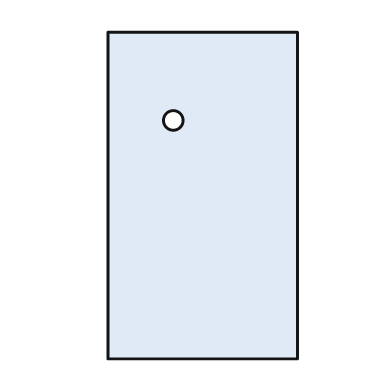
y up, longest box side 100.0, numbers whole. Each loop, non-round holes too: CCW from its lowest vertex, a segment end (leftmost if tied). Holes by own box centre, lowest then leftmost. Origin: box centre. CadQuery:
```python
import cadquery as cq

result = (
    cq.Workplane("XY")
    .moveTo(-29.0, -50.0)
    .lineTo(29.0, -50.0)
    .lineTo(29.0, 50.0)
    .lineTo(-29.0, 50.0)
    .close()
    .moveTo(-9.0, 23.0)
    .circle(3.0)
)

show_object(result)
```